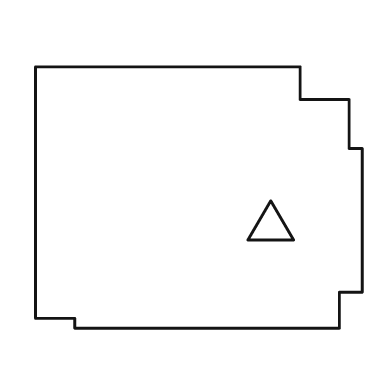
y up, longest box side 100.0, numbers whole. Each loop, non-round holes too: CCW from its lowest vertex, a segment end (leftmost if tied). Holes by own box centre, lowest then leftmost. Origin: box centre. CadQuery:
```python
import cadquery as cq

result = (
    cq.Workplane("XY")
    .moveTo(-38.0, -40.0)
    .lineTo(43.0, -40.0)
    .lineTo(43.0, -29.0)
    .lineTo(50.0, -29.0)
    .lineTo(50.0, 15.0)
    .lineTo(46.0, 15.0)
    .lineTo(46.0, 30.0)
    .lineTo(31.0, 30.0)
    .lineTo(31.0, 40.0)
    .lineTo(-50.0, 40.0)
    .lineTo(-50.0, -37.0)
    .lineTo(-38.0, -37.0)
    .close()
    .moveTo(15.0, -13.0)
    .lineTo(29.0, -13.0)
    .lineTo(22.0, -1.0)
    .close()
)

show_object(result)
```